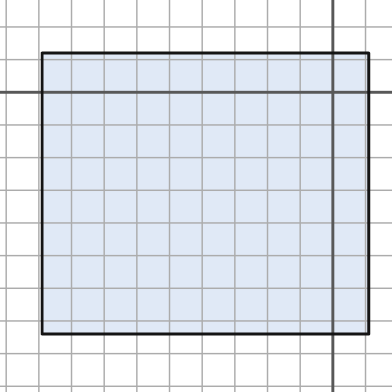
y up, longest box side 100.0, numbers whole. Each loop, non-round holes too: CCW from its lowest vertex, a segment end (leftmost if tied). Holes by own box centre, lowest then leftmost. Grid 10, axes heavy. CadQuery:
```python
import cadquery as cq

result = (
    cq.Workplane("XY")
    .moveTo(-89.0, -74.0)
    .lineTo(11.0, -74.0)
    .lineTo(11.0, 12.0)
    .lineTo(-89.0, 12.0)
    .close()
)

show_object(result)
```